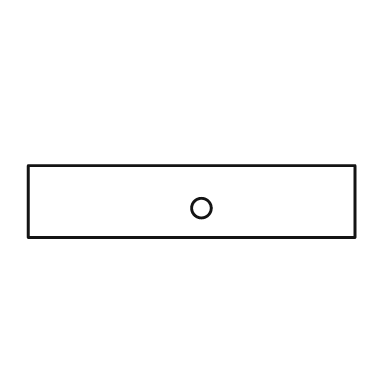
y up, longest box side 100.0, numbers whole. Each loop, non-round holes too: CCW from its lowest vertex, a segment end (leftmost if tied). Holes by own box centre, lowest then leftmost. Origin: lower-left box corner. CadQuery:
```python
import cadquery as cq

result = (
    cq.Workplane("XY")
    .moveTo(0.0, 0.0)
    .lineTo(100.0, 0.0)
    .lineTo(100.0, 22.0)
    .lineTo(0.0, 22.0)
    .close()
    .moveTo(53.0, 9.0)
    .circle(3.0)
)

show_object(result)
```